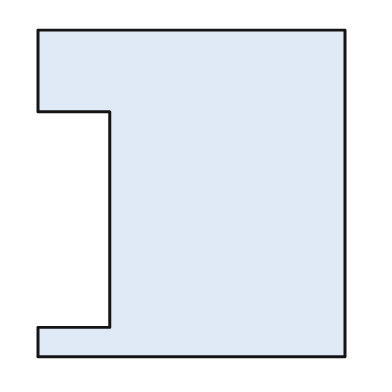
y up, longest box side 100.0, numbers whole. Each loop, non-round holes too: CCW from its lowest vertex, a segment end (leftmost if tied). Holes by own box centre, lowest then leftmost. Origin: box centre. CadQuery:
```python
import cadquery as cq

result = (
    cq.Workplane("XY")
    .moveTo(-47.0, -50.0)
    .lineTo(47.0, -50.0)
    .lineTo(47.0, 50.0)
    .lineTo(-47.0, 50.0)
    .lineTo(-47.0, 25.0)
    .lineTo(-25.0, 25.0)
    .lineTo(-25.0, -41.0)
    .lineTo(-47.0, -41.0)
    .close()
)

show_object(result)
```